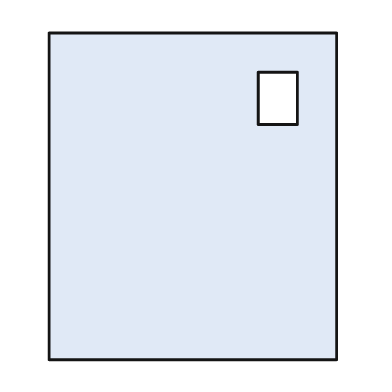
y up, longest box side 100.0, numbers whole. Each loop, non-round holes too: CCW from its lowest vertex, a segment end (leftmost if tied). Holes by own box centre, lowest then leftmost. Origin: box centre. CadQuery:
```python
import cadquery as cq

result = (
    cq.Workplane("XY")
    .moveTo(-44.0, -50.0)
    .lineTo(44.0, -50.0)
    .lineTo(44.0, 50.0)
    .lineTo(-44.0, 50.0)
    .close()
    .moveTo(20.0, 22.0)
    .lineTo(32.0, 22.0)
    .lineTo(32.0, 38.0)
    .lineTo(20.0, 38.0)
    .close()
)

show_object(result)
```